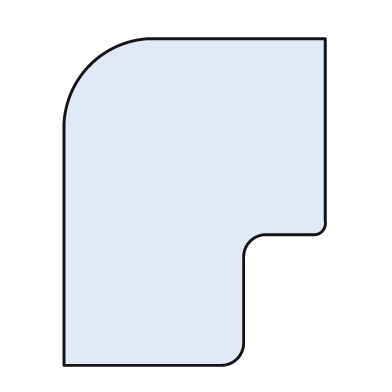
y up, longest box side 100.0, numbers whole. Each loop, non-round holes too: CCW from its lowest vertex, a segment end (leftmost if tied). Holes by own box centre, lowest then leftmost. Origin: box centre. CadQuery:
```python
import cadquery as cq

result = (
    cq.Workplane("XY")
    .moveTo(-40.0, -50.0)
    .lineTo(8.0, -50.0)
    .threePointArc((13.0, -48.0), (15.0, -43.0))
    .lineTo(15.0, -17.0)
    .threePointArc((17.0, -12.0), (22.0, -10.0))
    .lineTo(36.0, -10.0)
    .threePointArc((39.0, -9.0), (40.0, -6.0))
    .lineTo(40.0, 50.0)
    .lineTo(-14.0, 50.0)
    .threePointArc((-32.0, 42.0), (-40.0, 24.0))
    .close()
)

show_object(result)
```